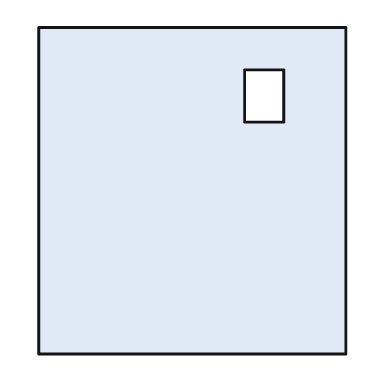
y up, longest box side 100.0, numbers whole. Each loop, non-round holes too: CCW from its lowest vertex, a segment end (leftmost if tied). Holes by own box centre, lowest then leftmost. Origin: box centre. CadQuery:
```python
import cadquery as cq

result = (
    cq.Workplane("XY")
    .moveTo(-47.0, -50.0)
    .lineTo(47.0, -50.0)
    .lineTo(47.0, 50.0)
    .lineTo(-47.0, 50.0)
    .close()
    .moveTo(16.0, 21.0)
    .lineTo(28.0, 21.0)
    .lineTo(28.0, 37.0)
    .lineTo(16.0, 37.0)
    .close()
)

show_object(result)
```